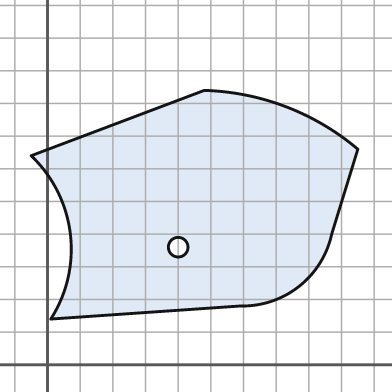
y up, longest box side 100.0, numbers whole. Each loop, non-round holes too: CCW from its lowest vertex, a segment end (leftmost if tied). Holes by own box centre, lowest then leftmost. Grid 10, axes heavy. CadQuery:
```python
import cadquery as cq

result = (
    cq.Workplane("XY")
    .moveTo(1.0, 14.0)
    .lineTo(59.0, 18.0)
    .threePointArc((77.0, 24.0), (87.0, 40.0))
    .lineTo(95.0, 66.0)
    .threePointArc((73.0, 79.0), (48.0, 84.0))
    .lineTo(-5.0, 64.0)
    .threePointArc((7.0, 40.0), (1.0, 14.0))
    .close()
    .moveTo(40.0, 36.0)
    .circle(3.0)
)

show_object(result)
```